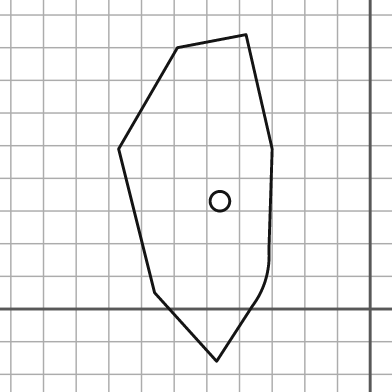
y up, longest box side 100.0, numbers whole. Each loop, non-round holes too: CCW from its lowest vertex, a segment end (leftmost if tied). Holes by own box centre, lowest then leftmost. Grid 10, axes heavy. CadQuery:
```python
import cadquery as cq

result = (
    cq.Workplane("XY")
    .moveTo(-47.0, -16.0)
    .lineTo(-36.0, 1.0)
    .threePointArc((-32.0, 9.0), (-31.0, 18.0))
    .lineTo(-30.0, 49.0)
    .lineTo(-38.0, 84.0)
    .lineTo(-59.0, 80.0)
    .lineTo(-77.0, 49.0)
    .lineTo(-66.0, 5.0)
    .close()
    .moveTo(-46.0, 33.0)
    .circle(3.0)
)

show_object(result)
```